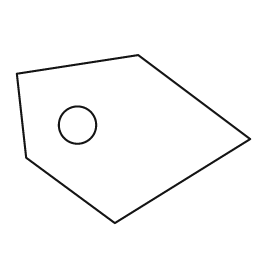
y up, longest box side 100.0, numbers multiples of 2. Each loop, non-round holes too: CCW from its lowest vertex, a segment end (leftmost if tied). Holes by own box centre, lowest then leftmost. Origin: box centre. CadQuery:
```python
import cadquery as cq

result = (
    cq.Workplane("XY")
    .moveTo(-8.0, -36.0)
    .lineTo(50.0, 0.0)
    .lineTo(2.0, 36.0)
    .lineTo(-50.0, 28.0)
    .lineTo(-46.0, -8.0)
    .close()
    .moveTo(-24.0, 6.0)
    .circle(8.0)
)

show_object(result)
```